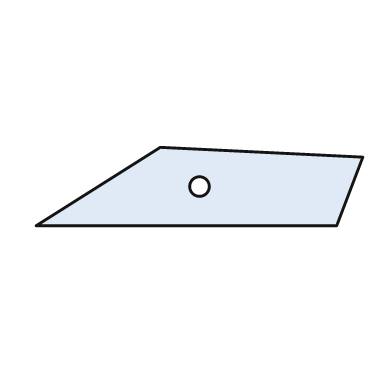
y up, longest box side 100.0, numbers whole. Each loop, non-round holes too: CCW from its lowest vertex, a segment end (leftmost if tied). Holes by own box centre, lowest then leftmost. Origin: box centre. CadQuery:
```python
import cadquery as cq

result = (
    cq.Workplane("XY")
    .moveTo(-50.0, -12.0)
    .lineTo(42.0, -12.0)
    .lineTo(50.0, 9.0)
    .lineTo(-12.0, 12.0)
    .close()
    .moveTo(0.0, 0.0)
    .circle(3.0)
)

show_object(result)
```